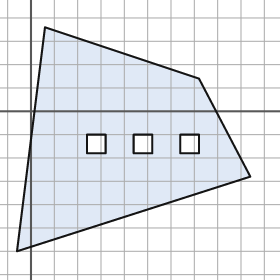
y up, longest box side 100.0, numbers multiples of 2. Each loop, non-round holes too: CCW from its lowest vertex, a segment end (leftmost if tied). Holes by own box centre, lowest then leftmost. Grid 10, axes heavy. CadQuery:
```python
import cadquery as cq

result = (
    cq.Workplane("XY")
    .moveTo(-6.0, -60.0)
    .lineTo(94.0, -28.0)
    .lineTo(72.0, 14.0)
    .lineTo(6.0, 36.0)
    .close()
    .moveTo(24.0, -18.0)
    .lineTo(32.0, -18.0)
    .lineTo(32.0, -10.0)
    .lineTo(24.0, -10.0)
    .close()
    .moveTo(44.0, -18.0)
    .lineTo(52.0, -18.0)
    .lineTo(52.0, -10.0)
    .lineTo(44.0, -10.0)
    .close()
    .moveTo(64.0, -18.0)
    .lineTo(72.0, -18.0)
    .lineTo(72.0, -10.0)
    .lineTo(64.0, -10.0)
    .close()
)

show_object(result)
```